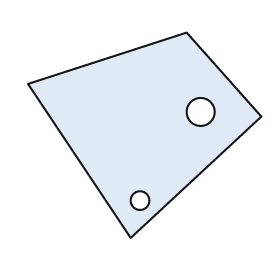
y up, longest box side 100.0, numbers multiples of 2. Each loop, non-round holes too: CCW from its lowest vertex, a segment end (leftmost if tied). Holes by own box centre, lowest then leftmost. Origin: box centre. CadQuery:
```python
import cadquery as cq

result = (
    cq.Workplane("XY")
    .moveTo(-6.0, -44.0)
    .lineTo(50.0, 8.0)
    .lineTo(18.0, 44.0)
    .lineTo(-50.0, 22.0)
    .close()
    .moveTo(-2.0, -28.0)
    .circle(4.0)
    .moveTo(24.0, 10.0)
    .circle(6.0)
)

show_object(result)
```